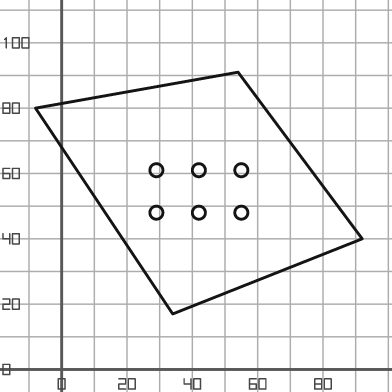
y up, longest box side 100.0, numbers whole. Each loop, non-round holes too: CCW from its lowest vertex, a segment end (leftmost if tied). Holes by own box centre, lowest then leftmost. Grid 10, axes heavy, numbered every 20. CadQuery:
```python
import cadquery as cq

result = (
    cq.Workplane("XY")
    .moveTo(34.0, 17.0)
    .lineTo(92.0, 40.0)
    .lineTo(54.0, 91.0)
    .lineTo(-8.0, 80.0)
    .close()
    .moveTo(29.0, 48.0)
    .circle(2.0)
    .moveTo(42.0, 48.0)
    .circle(2.0)
    .moveTo(55.0, 48.0)
    .circle(2.0)
    .moveTo(29.0, 61.0)
    .circle(2.0)
    .moveTo(42.0, 61.0)
    .circle(2.0)
    .moveTo(55.0, 61.0)
    .circle(2.0)
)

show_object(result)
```